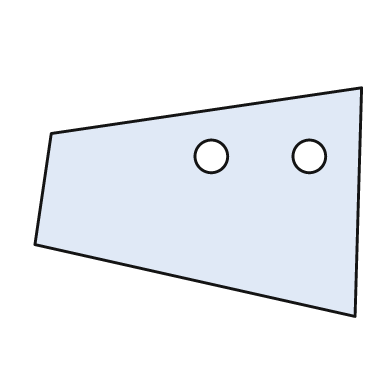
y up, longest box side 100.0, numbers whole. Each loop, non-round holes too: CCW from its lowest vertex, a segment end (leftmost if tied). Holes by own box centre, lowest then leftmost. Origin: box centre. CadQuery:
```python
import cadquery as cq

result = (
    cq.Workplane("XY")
    .moveTo(48.0, -35.0)
    .lineTo(50.0, 35.0)
    .lineTo(-45.0, 21.0)
    .lineTo(-50.0, -13.0)
    .close()
    .moveTo(4.0, 14.0)
    .circle(5.0)
    .moveTo(34.0, 14.0)
    .circle(5.0)
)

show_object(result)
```